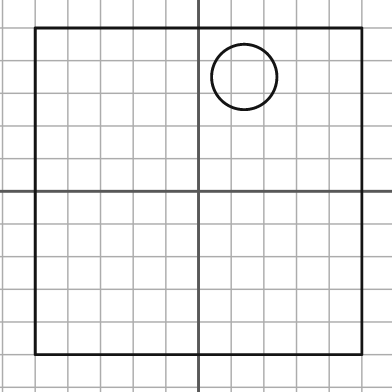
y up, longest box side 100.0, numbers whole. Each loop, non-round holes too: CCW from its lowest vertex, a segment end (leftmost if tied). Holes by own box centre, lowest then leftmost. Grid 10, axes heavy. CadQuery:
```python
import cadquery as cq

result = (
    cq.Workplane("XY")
    .moveTo(-50.0, -50.0)
    .lineTo(50.0, -50.0)
    .lineTo(50.0, 50.0)
    .lineTo(-50.0, 50.0)
    .close()
    .moveTo(14.0, 35.0)
    .circle(10.0)
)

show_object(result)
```